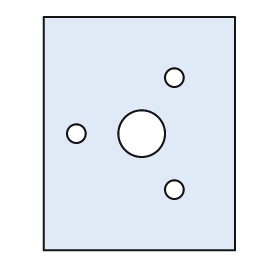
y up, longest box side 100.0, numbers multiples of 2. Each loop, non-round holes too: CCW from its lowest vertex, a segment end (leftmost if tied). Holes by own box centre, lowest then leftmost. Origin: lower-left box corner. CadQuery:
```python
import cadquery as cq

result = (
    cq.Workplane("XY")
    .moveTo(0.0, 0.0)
    .lineTo(82.0, 0.0)
    .lineTo(82.0, 100.0)
    .lineTo(0.0, 100.0)
    .close()
    .moveTo(56.0, 26.0)
    .circle(4.0)
    .moveTo(14.0, 50.0)
    .circle(4.0)
    .moveTo(42.0, 50.0)
    .circle(10.0)
    .moveTo(56.0, 74.0)
    .circle(4.0)
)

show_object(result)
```